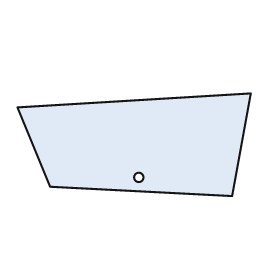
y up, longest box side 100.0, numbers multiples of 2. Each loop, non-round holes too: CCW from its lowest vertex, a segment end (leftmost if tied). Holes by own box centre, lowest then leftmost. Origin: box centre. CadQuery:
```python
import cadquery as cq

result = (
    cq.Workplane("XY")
    .moveTo(42.0, -22.0)
    .lineTo(50.0, 22.0)
    .lineTo(-50.0, 16.0)
    .lineTo(-36.0, -18.0)
    .close()
    .moveTo(2.0, -14.0)
    .circle(2.0)
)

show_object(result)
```